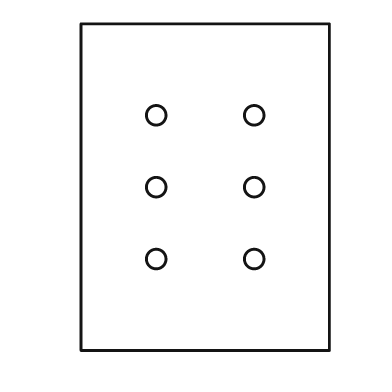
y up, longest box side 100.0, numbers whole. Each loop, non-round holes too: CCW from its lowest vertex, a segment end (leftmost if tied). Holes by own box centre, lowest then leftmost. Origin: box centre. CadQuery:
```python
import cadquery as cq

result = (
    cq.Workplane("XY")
    .moveTo(-38.0, -50.0)
    .lineTo(38.0, -50.0)
    .lineTo(38.0, 50.0)
    .lineTo(-38.0, 50.0)
    .close()
    .moveTo(-15.0, -22.0)
    .circle(3.0)
    .moveTo(15.0, -22.0)
    .circle(3.0)
    .moveTo(-15.0, 0.0)
    .circle(3.0)
    .moveTo(15.0, 0.0)
    .circle(3.0)
    .moveTo(-15.0, 22.0)
    .circle(3.0)
    .moveTo(15.0, 22.0)
    .circle(3.0)
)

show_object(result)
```